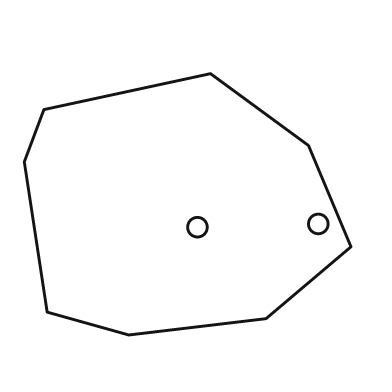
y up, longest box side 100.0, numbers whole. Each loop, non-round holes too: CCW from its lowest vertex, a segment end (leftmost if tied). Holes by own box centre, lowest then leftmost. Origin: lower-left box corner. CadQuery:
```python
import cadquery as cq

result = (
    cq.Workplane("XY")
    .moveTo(32.0, 0.0)
    .lineTo(74.0, 5.0)
    .lineTo(100.0, 27.0)
    .lineTo(87.0, 58.0)
    .lineTo(57.0, 80.0)
    .lineTo(6.0, 69.0)
    .lineTo(0.0, 53.0)
    .lineTo(7.0, 7.0)
    .close()
    .moveTo(53.0, 33.0)
    .circle(3.0)
    .moveTo(90.0, 34.0)
    .circle(3.0)
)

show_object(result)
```